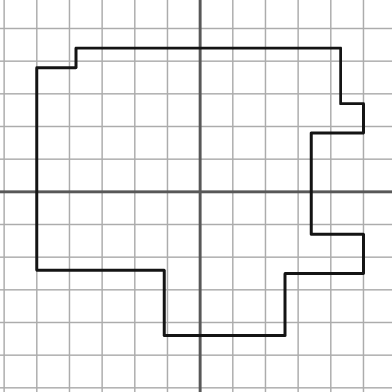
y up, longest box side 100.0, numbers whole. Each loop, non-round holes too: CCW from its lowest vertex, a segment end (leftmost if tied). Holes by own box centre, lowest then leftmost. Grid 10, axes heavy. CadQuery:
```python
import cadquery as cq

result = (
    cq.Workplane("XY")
    .moveTo(-11.0, -44.0)
    .lineTo(26.0, -44.0)
    .lineTo(26.0, -25.0)
    .lineTo(50.0, -25.0)
    .lineTo(50.0, -13.0)
    .lineTo(34.0, -13.0)
    .lineTo(34.0, 18.0)
    .lineTo(50.0, 18.0)
    .lineTo(50.0, 27.0)
    .lineTo(43.0, 27.0)
    .lineTo(43.0, 44.0)
    .lineTo(-38.0, 44.0)
    .lineTo(-38.0, 38.0)
    .lineTo(-50.0, 38.0)
    .lineTo(-50.0, -24.0)
    .lineTo(-11.0, -24.0)
    .close()
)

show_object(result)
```